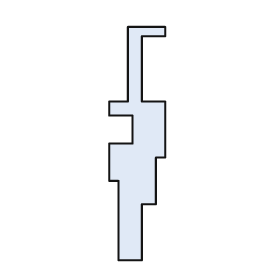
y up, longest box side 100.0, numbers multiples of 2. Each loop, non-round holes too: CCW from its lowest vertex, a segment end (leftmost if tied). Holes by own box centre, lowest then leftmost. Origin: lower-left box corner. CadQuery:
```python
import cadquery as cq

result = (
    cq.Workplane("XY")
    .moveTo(4.0, 0.0)
    .lineTo(14.0, 0.0)
    .lineTo(14.0, 24.0)
    .lineTo(20.0, 24.0)
    .lineTo(20.0, 44.0)
    .lineTo(24.0, 44.0)
    .lineTo(24.0, 68.0)
    .lineTo(14.0, 68.0)
    .lineTo(14.0, 96.0)
    .lineTo(24.0, 96.0)
    .lineTo(24.0, 100.0)
    .lineTo(8.0, 100.0)
    .lineTo(8.0, 68.0)
    .lineTo(0.0, 68.0)
    .lineTo(0.0, 62.0)
    .lineTo(10.0, 62.0)
    .lineTo(10.0, 50.0)
    .lineTo(0.0, 50.0)
    .lineTo(0.0, 34.0)
    .lineTo(4.0, 34.0)
    .close()
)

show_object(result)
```